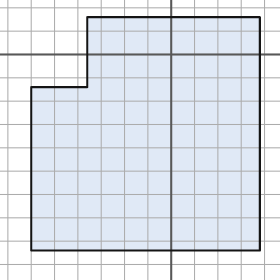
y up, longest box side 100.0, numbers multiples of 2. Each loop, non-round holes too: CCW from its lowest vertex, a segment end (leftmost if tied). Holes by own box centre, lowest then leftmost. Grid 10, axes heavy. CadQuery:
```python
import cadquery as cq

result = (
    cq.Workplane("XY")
    .moveTo(-60.0, -84.0)
    .lineTo(38.0, -84.0)
    .lineTo(38.0, 16.0)
    .lineTo(-36.0, 16.0)
    .lineTo(-36.0, -14.0)
    .lineTo(-60.0, -14.0)
    .close()
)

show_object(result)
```